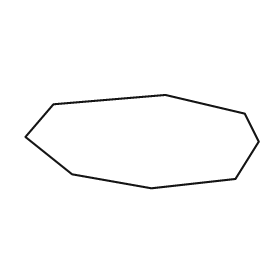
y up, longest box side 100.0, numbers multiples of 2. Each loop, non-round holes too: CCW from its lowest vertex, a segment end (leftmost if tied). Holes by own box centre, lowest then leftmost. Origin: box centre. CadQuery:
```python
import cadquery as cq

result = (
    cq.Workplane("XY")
    .moveTo(4.0, -20.0)
    .lineTo(40.0, -16.0)
    .lineTo(50.0, 0.0)
    .lineTo(44.0, 12.0)
    .lineTo(10.0, 20.0)
    .lineTo(-38.0, 16.0)
    .lineTo(-50.0, 2.0)
    .lineTo(-30.0, -14.0)
    .close()
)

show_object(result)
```